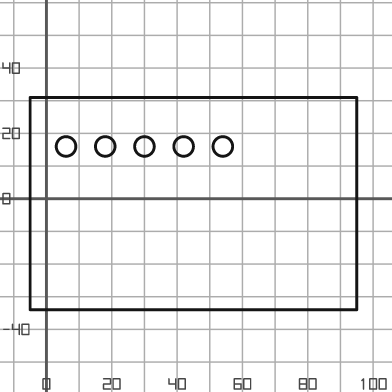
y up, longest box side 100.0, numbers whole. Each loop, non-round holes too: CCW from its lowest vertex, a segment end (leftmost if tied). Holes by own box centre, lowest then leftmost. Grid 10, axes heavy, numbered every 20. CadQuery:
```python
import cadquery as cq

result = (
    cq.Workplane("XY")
    .moveTo(-5.0, -34.0)
    .lineTo(95.0, -34.0)
    .lineTo(95.0, 31.0)
    .lineTo(-5.0, 31.0)
    .close()
    .moveTo(6.0, 16.0)
    .circle(3.0)
    .moveTo(18.0, 16.0)
    .circle(3.0)
    .moveTo(30.0, 16.0)
    .circle(3.0)
    .moveTo(42.0, 16.0)
    .circle(3.0)
    .moveTo(54.0, 16.0)
    .circle(3.0)
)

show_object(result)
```